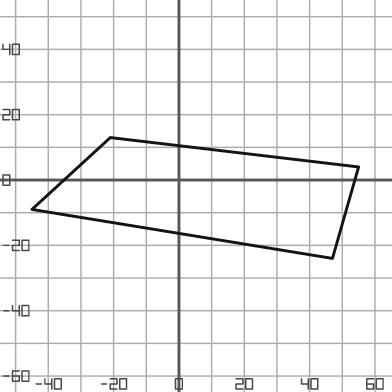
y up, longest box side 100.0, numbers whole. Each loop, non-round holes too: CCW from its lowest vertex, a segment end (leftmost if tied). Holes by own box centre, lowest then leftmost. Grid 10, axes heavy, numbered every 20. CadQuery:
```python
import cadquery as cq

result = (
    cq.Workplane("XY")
    .moveTo(47.0, -24.0)
    .lineTo(55.0, 4.0)
    .lineTo(-21.0, 13.0)
    .lineTo(-45.0, -9.0)
    .close()
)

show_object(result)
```